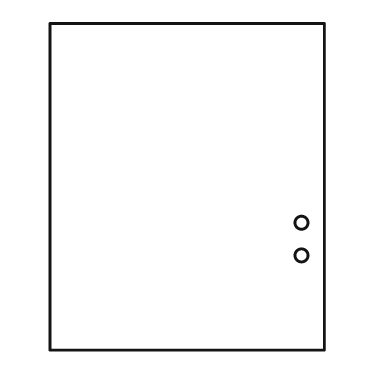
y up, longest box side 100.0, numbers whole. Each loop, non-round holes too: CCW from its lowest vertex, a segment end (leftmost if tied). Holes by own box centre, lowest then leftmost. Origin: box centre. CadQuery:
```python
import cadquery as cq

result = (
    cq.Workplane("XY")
    .moveTo(-42.0, -50.0)
    .lineTo(42.0, -50.0)
    .lineTo(42.0, 50.0)
    .lineTo(-42.0, 50.0)
    .close()
    .moveTo(35.0, -21.0)
    .circle(2.0)
    .moveTo(35.0, -11.0)
    .circle(2.0)
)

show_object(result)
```